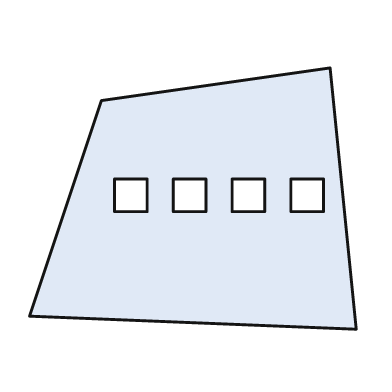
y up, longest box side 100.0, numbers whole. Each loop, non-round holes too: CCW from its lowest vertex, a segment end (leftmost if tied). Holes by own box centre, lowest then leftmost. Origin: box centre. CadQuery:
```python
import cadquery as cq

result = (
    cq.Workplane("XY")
    .moveTo(50.0, -40.0)
    .lineTo(42.0, 40.0)
    .lineTo(-28.0, 30.0)
    .lineTo(-50.0, -36.0)
    .close()
    .moveTo(-24.0, -4.0)
    .lineTo(-14.0, -4.0)
    .lineTo(-14.0, 6.0)
    .lineTo(-24.0, 6.0)
    .close()
    .moveTo(-6.0, -4.0)
    .lineTo(4.0, -4.0)
    .lineTo(4.0, 6.0)
    .lineTo(-6.0, 6.0)
    .close()
    .moveTo(12.0, -4.0)
    .lineTo(22.0, -4.0)
    .lineTo(22.0, 6.0)
    .lineTo(12.0, 6.0)
    .close()
    .moveTo(30.0, -4.0)
    .lineTo(40.0, -4.0)
    .lineTo(40.0, 6.0)
    .lineTo(30.0, 6.0)
    .close()
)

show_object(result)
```